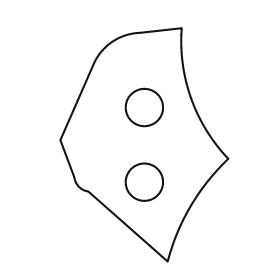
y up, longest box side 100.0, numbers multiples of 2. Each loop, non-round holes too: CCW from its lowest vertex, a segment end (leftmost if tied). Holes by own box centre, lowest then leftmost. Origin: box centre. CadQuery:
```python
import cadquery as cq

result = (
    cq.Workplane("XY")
    .moveTo(10.0, -50.0)
    .threePointArc((20.0, -26.0), (36.0, -6.0))
    .threePointArc((20.0, 20.0), (16.0, 50.0))
    .lineTo(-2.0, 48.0)
    .threePointArc((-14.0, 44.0), (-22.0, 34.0))
    .lineTo(-36.0, 2.0)
    .lineTo(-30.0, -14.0)
    .threePointArc((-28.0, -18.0), (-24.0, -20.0))
    .close()
    .moveTo(0.0, -16.0)
    .circle(8.0)
    .moveTo(0.0, 16.0)
    .circle(8.0)
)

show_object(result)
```